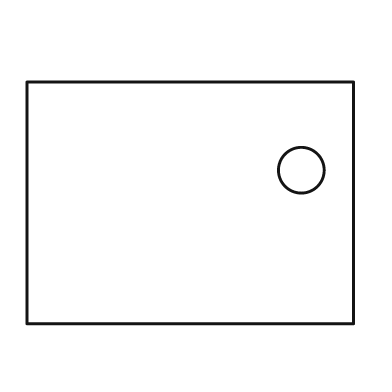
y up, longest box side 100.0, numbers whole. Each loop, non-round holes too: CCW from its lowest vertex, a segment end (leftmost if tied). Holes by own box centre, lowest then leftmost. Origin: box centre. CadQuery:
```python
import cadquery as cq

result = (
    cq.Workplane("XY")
    .moveTo(-50.0, -37.0)
    .lineTo(50.0, -37.0)
    .lineTo(50.0, 37.0)
    .lineTo(-50.0, 37.0)
    .close()
    .moveTo(34.0, 10.0)
    .circle(7.0)
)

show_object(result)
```